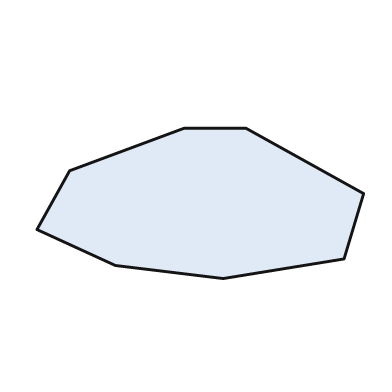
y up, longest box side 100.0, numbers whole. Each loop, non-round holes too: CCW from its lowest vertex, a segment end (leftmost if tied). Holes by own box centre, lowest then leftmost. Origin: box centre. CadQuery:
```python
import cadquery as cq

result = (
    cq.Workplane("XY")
    .moveTo(7.0, -23.0)
    .lineTo(44.0, -17.0)
    .lineTo(50.0, 3.0)
    .lineTo(14.0, 23.0)
    .lineTo(-5.0, 23.0)
    .lineTo(-40.0, 10.0)
    .lineTo(-50.0, -8.0)
    .lineTo(-26.0, -19.0)
    .close()
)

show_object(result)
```